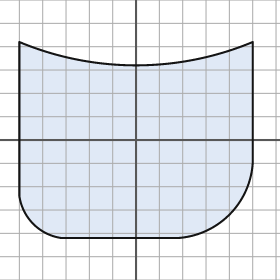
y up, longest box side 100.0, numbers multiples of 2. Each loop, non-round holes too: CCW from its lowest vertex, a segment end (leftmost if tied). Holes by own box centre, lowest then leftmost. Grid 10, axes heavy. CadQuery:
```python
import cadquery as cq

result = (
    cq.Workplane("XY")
    .moveTo(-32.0, -42.0)
    .lineTo(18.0, -42.0)
    .threePointArc((40.0, -32.0), (50.0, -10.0))
    .lineTo(50.0, 42.0)
    .threePointArc((0.0, 32.0), (-50.0, 42.0))
    .lineTo(-50.0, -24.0)
    .threePointArc((-44.0, -36.0), (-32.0, -42.0))
    .close()
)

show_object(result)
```